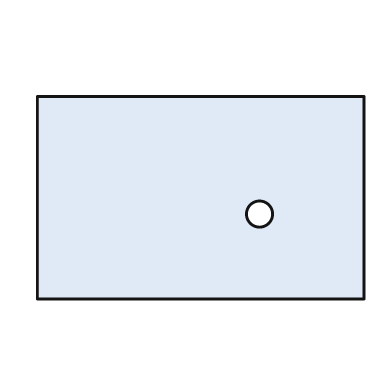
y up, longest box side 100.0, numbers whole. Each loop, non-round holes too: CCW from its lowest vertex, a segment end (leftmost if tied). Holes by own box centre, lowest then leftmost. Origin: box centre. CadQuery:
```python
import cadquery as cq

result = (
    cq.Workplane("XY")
    .moveTo(-50.0, -31.0)
    .lineTo(50.0, -31.0)
    .lineTo(50.0, 31.0)
    .lineTo(-50.0, 31.0)
    .close()
    .moveTo(18.0, -5.0)
    .circle(4.0)
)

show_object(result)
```